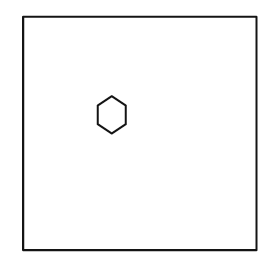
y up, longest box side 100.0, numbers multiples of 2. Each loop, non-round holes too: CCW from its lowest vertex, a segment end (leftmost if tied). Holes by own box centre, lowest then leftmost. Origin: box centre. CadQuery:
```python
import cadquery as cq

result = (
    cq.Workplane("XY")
    .moveTo(-50.0, -50.0)
    .lineTo(50.0, -50.0)
    .lineTo(50.0, 50.0)
    .lineTo(-50.0, 50.0)
    .close()
    .moveTo(-12.0, 0.0)
    .lineTo(-6.0, 4.0)
    .lineTo(-6.0, 12.0)
    .lineTo(-12.0, 16.0)
    .lineTo(-18.0, 12.0)
    .lineTo(-18.0, 4.0)
    .close()
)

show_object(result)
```